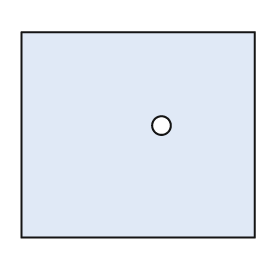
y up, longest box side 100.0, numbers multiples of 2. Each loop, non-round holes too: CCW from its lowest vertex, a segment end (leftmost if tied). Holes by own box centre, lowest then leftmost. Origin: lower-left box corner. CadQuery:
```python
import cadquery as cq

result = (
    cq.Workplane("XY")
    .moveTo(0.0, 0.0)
    .lineTo(100.0, 0.0)
    .lineTo(100.0, 88.0)
    .lineTo(0.0, 88.0)
    .close()
    .moveTo(60.0, 48.0)
    .circle(4.0)
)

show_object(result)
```